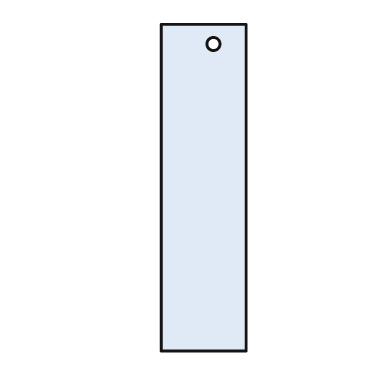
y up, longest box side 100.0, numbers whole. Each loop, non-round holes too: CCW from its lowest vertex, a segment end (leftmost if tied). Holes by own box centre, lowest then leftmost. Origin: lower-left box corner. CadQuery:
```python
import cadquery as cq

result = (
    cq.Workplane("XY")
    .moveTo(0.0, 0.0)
    .lineTo(26.0, 0.0)
    .lineTo(26.0, 100.0)
    .lineTo(0.0, 100.0)
    .close()
    .moveTo(16.0, 94.0)
    .circle(2.0)
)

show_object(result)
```